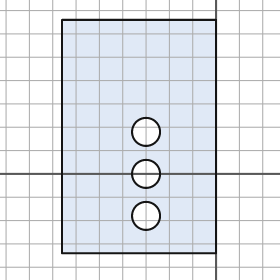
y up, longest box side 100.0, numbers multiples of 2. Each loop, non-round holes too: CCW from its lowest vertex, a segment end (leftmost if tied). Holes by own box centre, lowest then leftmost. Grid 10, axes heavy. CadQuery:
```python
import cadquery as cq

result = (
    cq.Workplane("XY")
    .moveTo(-66.0, -34.0)
    .lineTo(0.0, -34.0)
    .lineTo(0.0, 66.0)
    .lineTo(-66.0, 66.0)
    .close()
    .moveTo(-30.0, -18.0)
    .circle(6.0)
    .moveTo(-30.0, 0.0)
    .circle(6.0)
    .moveTo(-30.0, 18.0)
    .circle(6.0)
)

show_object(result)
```